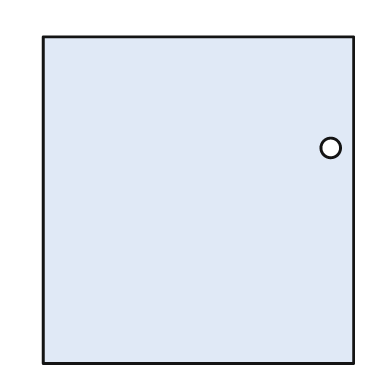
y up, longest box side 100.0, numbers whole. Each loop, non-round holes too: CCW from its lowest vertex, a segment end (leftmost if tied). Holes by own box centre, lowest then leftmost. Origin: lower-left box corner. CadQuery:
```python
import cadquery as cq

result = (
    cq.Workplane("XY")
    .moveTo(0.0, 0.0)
    .lineTo(95.0, 0.0)
    .lineTo(95.0, 100.0)
    .lineTo(0.0, 100.0)
    .close()
    .moveTo(88.0, 66.0)
    .circle(3.0)
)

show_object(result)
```